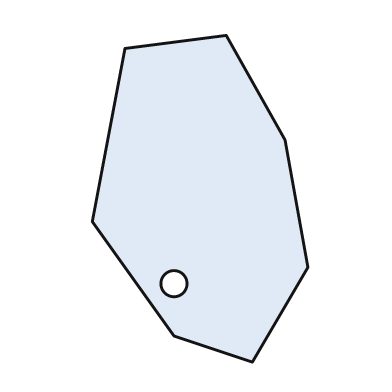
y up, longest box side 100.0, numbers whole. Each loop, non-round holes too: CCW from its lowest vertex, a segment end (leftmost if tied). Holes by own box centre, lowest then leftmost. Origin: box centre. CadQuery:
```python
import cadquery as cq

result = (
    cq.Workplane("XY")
    .moveTo(16.0, -50.0)
    .lineTo(33.0, -21.0)
    .lineTo(26.0, 18.0)
    .lineTo(8.0, 50.0)
    .lineTo(-23.0, 46.0)
    .lineTo(-33.0, -7.0)
    .lineTo(-8.0, -42.0)
    .close()
    .moveTo(-8.0, -26.0)
    .circle(4.0)
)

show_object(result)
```